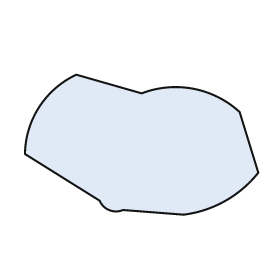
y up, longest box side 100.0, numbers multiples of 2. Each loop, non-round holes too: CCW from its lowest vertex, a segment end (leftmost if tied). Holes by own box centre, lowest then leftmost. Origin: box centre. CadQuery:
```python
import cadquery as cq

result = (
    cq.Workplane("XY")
    .moveTo(18.0, -30.0)
    .threePointArc((36.0, -24.0), (50.0, -12.0))
    .lineTo(42.0, 14.0)
    .threePointArc((22.0, 24.0), (0.0, 22.0))
    .lineTo(-28.0, 30.0)
    .threePointArc((-44.0, 16.0), (-50.0, -4.0))
    .lineTo(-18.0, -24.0)
    .threePointArc((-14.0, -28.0), (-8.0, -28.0))
    .close()
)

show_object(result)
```